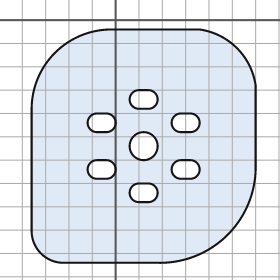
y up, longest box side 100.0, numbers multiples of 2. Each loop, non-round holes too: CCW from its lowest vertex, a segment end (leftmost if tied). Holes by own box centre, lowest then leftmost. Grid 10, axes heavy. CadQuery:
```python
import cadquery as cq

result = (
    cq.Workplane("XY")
    .moveTo(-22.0, -104.0)
    .lineTo(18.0, -104.0)
    .threePointArc((48.0, -92.0), (60.0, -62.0))
    .lineTo(60.0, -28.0)
    .threePointArc((52.0, -12.0), (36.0, -4.0))
    .lineTo(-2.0, -4.0)
    .threePointArc((-26.0, -14.0), (-36.0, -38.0))
    .lineTo(-36.0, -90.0)
    .threePointArc((-32.0, -100.0), (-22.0, -104.0))
    .close()
    .moveTo(10.0, -78.0)
    .lineTo(14.0, -78.0)
    .threePointArc((18.0, -74.0), (14.0, -70.0))
    .lineTo(10.0, -70.0)
    .threePointArc((6.0, -74.0), (10.0, -78.0))
    .close()
    .moveTo(-8.0, -68.0)
    .lineTo(-4.0, -68.0)
    .threePointArc((0.0, -64.0), (-4.0, -60.0))
    .lineTo(-8.0, -60.0)
    .threePointArc((-12.0, -64.0), (-8.0, -68.0))
    .close()
    .moveTo(28.0, -68.0)
    .lineTo(32.0, -68.0)
    .threePointArc((36.0, -64.0), (32.0, -60.0))
    .lineTo(28.0, -60.0)
    .threePointArc((24.0, -64.0), (28.0, -68.0))
    .close()
    .moveTo(12.0, -54.0)
    .circle(6.0)
    .moveTo(-8.0, -48.0)
    .lineTo(-4.0, -48.0)
    .threePointArc((0.0, -44.0), (-4.0, -40.0))
    .lineTo(-8.0, -40.0)
    .threePointArc((-12.0, -44.0), (-8.0, -48.0))
    .close()
    .moveTo(28.0, -48.0)
    .lineTo(32.0, -48.0)
    .threePointArc((36.0, -44.0), (32.0, -40.0))
    .lineTo(28.0, -40.0)
    .threePointArc((24.0, -44.0), (28.0, -48.0))
    .close()
    .moveTo(10.0, -38.0)
    .lineTo(14.0, -38.0)
    .threePointArc((18.0, -34.0), (14.0, -30.0))
    .lineTo(10.0, -30.0)
    .threePointArc((6.0, -34.0), (10.0, -38.0))
    .close()
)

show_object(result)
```